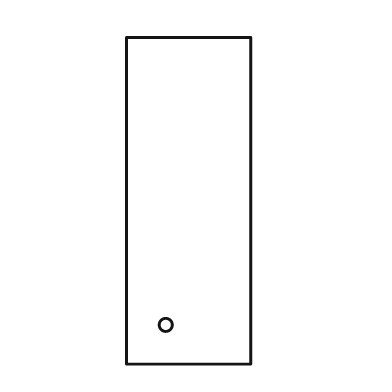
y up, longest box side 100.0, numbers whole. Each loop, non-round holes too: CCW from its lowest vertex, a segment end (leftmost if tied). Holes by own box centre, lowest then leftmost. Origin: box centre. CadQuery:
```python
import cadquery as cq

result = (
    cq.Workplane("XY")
    .moveTo(-19.0, -50.0)
    .lineTo(19.0, -50.0)
    .lineTo(19.0, 50.0)
    .lineTo(-19.0, 50.0)
    .close()
    .moveTo(-7.0, -38.0)
    .circle(2.0)
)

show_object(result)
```